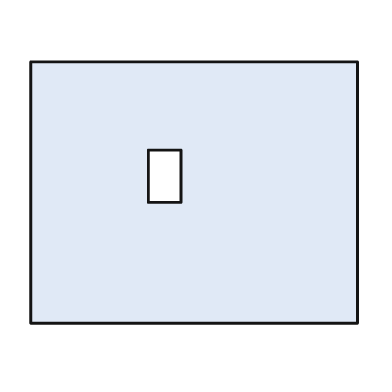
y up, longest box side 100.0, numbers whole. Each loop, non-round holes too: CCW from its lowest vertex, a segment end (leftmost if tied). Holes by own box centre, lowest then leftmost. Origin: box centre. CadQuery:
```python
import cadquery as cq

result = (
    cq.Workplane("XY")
    .moveTo(-50.0, -40.0)
    .lineTo(50.0, -40.0)
    .lineTo(50.0, 40.0)
    .lineTo(-50.0, 40.0)
    .close()
    .moveTo(-14.0, -3.0)
    .lineTo(-4.0, -3.0)
    .lineTo(-4.0, 13.0)
    .lineTo(-14.0, 13.0)
    .close()
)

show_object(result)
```